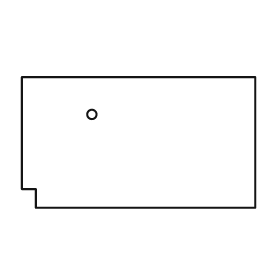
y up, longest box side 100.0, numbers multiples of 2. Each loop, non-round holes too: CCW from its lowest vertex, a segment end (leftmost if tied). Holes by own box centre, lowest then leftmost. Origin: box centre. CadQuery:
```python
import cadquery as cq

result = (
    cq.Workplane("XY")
    .moveTo(-44.0, -28.0)
    .lineTo(50.0, -28.0)
    .lineTo(50.0, 28.0)
    .lineTo(-50.0, 28.0)
    .lineTo(-50.0, -20.0)
    .lineTo(-44.0, -20.0)
    .close()
    .moveTo(-20.0, 12.0)
    .circle(2.0)
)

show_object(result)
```